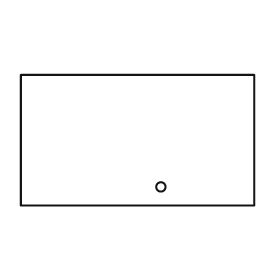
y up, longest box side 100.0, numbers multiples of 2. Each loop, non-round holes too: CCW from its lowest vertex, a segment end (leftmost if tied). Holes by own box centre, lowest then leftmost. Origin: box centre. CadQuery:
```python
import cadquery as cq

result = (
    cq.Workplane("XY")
    .moveTo(-50.0, -28.0)
    .lineTo(50.0, -28.0)
    .lineTo(50.0, 28.0)
    .lineTo(-50.0, 28.0)
    .close()
    .moveTo(10.0, -20.0)
    .circle(2.0)
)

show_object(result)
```